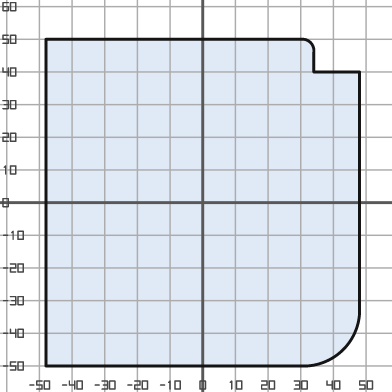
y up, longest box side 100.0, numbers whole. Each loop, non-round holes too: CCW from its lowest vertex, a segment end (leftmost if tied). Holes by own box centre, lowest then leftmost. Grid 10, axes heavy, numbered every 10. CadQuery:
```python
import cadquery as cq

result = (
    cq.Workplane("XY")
    .moveTo(-48.0, -50.0)
    .lineTo(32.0, -50.0)
    .threePointArc((43.0, -45.0), (48.0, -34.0))
    .lineTo(48.0, 40.0)
    .lineTo(34.0, 40.0)
    .lineTo(34.0, 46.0)
    .threePointArc((33.0, 49.0), (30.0, 50.0))
    .lineTo(-48.0, 50.0)
    .close()
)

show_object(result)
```